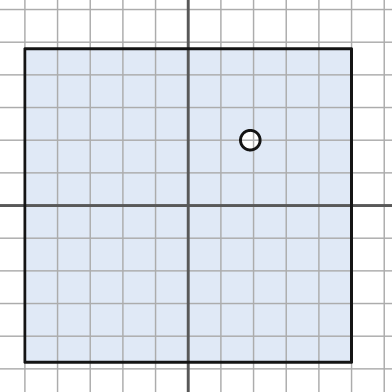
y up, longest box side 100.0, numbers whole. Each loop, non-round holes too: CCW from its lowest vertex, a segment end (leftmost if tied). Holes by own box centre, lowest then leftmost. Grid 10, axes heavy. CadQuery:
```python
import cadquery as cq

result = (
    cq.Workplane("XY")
    .moveTo(-50.0, -48.0)
    .lineTo(50.0, -48.0)
    .lineTo(50.0, 48.0)
    .lineTo(-50.0, 48.0)
    .close()
    .moveTo(19.0, 20.0)
    .circle(3.0)
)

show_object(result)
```